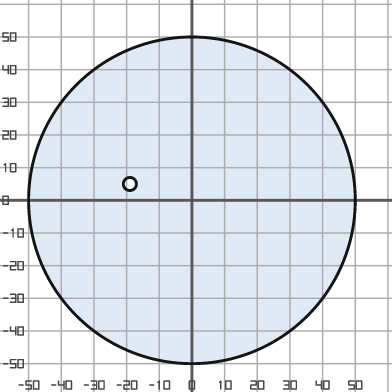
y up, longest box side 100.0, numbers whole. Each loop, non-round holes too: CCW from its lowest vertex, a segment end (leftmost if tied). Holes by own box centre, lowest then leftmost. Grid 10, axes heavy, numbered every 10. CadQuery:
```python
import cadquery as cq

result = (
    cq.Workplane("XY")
    .moveTo(0.0, 0.0)
    .circle(50.0)
    .moveTo(-19.0, 5.0)
    .circle(2.0)
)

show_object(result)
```